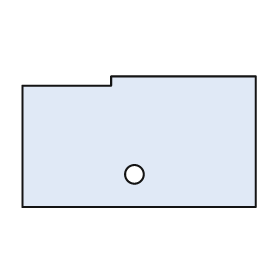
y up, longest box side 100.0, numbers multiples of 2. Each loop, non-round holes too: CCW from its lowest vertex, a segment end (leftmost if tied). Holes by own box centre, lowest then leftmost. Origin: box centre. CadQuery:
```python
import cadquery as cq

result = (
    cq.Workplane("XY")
    .moveTo(-50.0, -28.0)
    .lineTo(50.0, -28.0)
    .lineTo(50.0, 28.0)
    .lineTo(-12.0, 28.0)
    .lineTo(-12.0, 24.0)
    .lineTo(-50.0, 24.0)
    .close()
    .moveTo(-2.0, -14.0)
    .circle(4.0)
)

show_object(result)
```